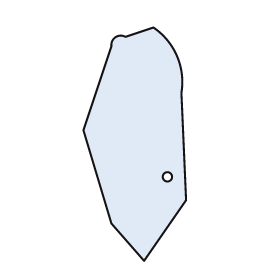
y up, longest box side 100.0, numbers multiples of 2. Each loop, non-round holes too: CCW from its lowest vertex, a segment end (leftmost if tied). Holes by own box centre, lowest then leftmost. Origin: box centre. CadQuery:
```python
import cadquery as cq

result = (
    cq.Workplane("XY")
    .moveTo(4.0, -50.0)
    .lineTo(22.0, -24.0)
    .lineTo(20.0, 22.0)
    .threePointArc((18.0, 38.0), (8.0, 50.0))
    .lineTo(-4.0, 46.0)
    .threePointArc((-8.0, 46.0), (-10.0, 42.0))
    .lineTo(-22.0, 6.0)
    .lineTo(-10.0, -34.0)
    .close()
    .moveTo(14.0, -14.0)
    .circle(2.0)
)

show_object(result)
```